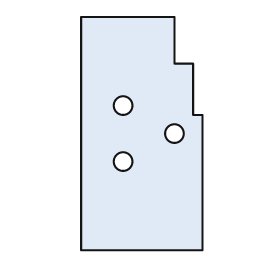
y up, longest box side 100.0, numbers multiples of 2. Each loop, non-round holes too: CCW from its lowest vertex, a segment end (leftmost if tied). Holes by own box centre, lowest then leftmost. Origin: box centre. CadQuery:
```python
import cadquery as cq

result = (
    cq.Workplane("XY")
    .moveTo(-26.0, -50.0)
    .lineTo(26.0, -50.0)
    .lineTo(26.0, 8.0)
    .lineTo(22.0, 8.0)
    .lineTo(22.0, 30.0)
    .lineTo(14.0, 30.0)
    .lineTo(14.0, 50.0)
    .lineTo(-26.0, 50.0)
    .close()
    .moveTo(-8.0, -12.0)
    .circle(4.0)
    .moveTo(14.0, 0.0)
    .circle(4.0)
    .moveTo(-8.0, 12.0)
    .circle(4.0)
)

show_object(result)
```